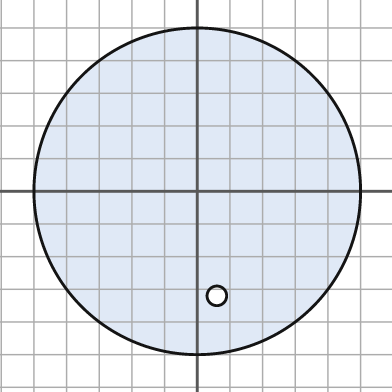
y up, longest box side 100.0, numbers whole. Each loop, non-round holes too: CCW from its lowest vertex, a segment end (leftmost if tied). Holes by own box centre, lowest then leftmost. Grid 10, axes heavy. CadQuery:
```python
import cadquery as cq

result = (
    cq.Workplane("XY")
    .moveTo(0.0, 0.0)
    .circle(50.0)
    .moveTo(6.0, -32.0)
    .circle(3.0)
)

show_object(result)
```